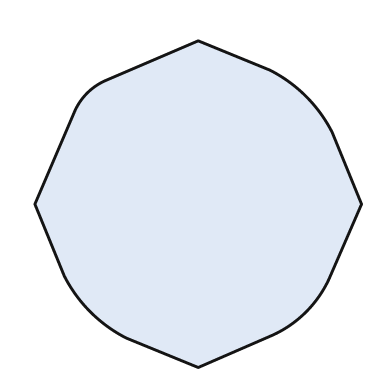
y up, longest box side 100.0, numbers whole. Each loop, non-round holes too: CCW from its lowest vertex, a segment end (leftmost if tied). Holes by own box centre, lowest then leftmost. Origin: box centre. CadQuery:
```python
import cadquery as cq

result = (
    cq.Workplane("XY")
    .moveTo(0.0, -50.0)
    .lineTo(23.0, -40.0)
    .threePointArc((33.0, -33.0), (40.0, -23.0))
    .lineTo(50.0, 0.0)
    .lineTo(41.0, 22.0)
    .threePointArc((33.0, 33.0), (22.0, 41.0))
    .lineTo(0.0, 50.0)
    .lineTo(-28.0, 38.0)
    .threePointArc((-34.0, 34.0), (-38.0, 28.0))
    .lineTo(-50.0, 0.0)
    .lineTo(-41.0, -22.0)
    .threePointArc((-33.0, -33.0), (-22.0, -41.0))
    .close()
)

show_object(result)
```